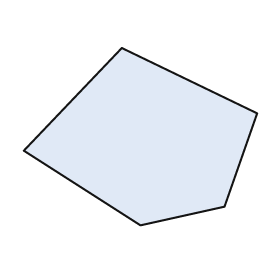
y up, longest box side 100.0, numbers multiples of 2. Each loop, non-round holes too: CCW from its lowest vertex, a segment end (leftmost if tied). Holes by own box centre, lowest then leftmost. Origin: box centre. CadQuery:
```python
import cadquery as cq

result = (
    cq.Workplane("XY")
    .moveTo(0.0, -38.0)
    .lineTo(36.0, -30.0)
    .lineTo(50.0, 10.0)
    .lineTo(-8.0, 38.0)
    .lineTo(-50.0, -6.0)
    .close()
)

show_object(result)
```